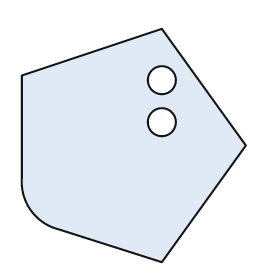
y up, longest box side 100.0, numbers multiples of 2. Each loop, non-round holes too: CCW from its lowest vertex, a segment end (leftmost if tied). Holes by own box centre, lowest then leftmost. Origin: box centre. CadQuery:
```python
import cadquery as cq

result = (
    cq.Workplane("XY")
    .moveTo(12.0, -50.0)
    .lineTo(48.0, 0.0)
    .lineTo(12.0, 50.0)
    .lineTo(-48.0, 30.0)
    .lineTo(-48.0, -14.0)
    .threePointArc((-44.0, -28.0), (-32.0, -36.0))
    .close()
    .moveTo(12.0, 10.0)
    .circle(6.0)
    .moveTo(12.0, 28.0)
    .circle(6.0)
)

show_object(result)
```